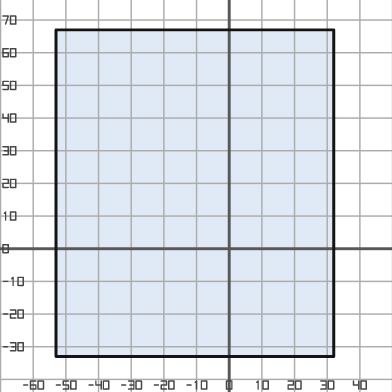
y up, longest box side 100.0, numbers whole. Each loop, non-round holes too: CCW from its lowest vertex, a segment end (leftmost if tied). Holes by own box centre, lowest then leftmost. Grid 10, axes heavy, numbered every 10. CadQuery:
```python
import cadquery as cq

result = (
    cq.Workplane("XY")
    .moveTo(-53.0, -33.0)
    .lineTo(32.0, -33.0)
    .lineTo(32.0, 67.0)
    .lineTo(-53.0, 67.0)
    .close()
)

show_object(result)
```